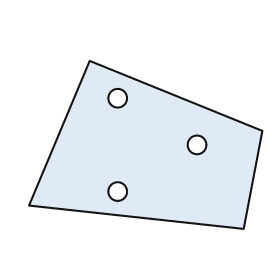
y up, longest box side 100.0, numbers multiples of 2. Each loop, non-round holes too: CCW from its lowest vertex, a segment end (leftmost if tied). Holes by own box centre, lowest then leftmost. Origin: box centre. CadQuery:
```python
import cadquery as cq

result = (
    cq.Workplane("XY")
    .moveTo(42.0, -36.0)
    .lineTo(50.0, 6.0)
    .lineTo(-24.0, 36.0)
    .lineTo(-50.0, -26.0)
    .close()
    .moveTo(-12.0, -20.0)
    .circle(4.0)
    .moveTo(22.0, 0.0)
    .circle(4.0)
    .moveTo(-12.0, 20.0)
    .circle(4.0)
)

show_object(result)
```